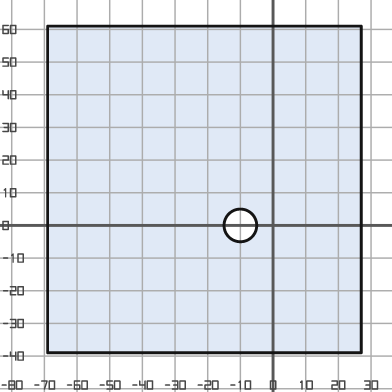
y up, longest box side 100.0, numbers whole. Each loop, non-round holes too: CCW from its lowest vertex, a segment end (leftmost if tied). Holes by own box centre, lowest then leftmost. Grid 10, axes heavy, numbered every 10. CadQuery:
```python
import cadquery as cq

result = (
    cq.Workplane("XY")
    .moveTo(-69.0, -39.0)
    .lineTo(27.0, -39.0)
    .lineTo(27.0, 61.0)
    .lineTo(-69.0, 61.0)
    .close()
    .moveTo(-10.0, 0.0)
    .circle(5.0)
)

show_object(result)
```